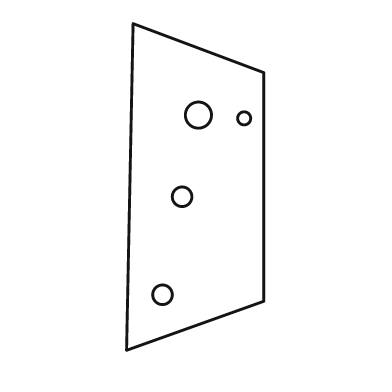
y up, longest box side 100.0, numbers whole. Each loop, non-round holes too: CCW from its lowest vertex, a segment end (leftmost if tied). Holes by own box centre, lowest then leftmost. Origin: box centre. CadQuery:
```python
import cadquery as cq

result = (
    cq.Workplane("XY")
    .moveTo(-21.0, -50.0)
    .lineTo(21.0, -35.0)
    .lineTo(21.0, 35.0)
    .lineTo(-19.0, 50.0)
    .close()
    .moveTo(-10.0, -33.0)
    .circle(3.0)
    .moveTo(-4.0, -3.0)
    .circle(3.0)
    .moveTo(15.0, 21.0)
    .circle(2.0)
    .moveTo(1.0, 22.0)
    .circle(4.0)
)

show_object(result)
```